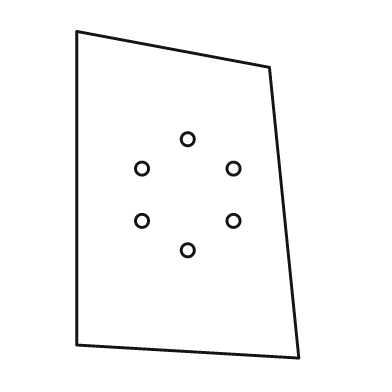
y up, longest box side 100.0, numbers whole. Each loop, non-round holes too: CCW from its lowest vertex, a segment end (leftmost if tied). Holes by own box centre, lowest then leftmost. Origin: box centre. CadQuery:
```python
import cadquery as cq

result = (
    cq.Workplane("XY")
    .moveTo(34.0, -50.0)
    .lineTo(25.0, 39.0)
    .lineTo(-34.0, 50.0)
    .lineTo(-34.0, -46.0)
    .close()
    .moveTo(0.0, -17.0)
    .circle(2.0)
    .moveTo(-14.0, -8.0)
    .circle(2.0)
    .moveTo(14.0, -8.0)
    .circle(2.0)
    .moveTo(-14.0, 8.0)
    .circle(2.0)
    .moveTo(14.0, 8.0)
    .circle(2.0)
    .moveTo(0.0, 17.0)
    .circle(2.0)
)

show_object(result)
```